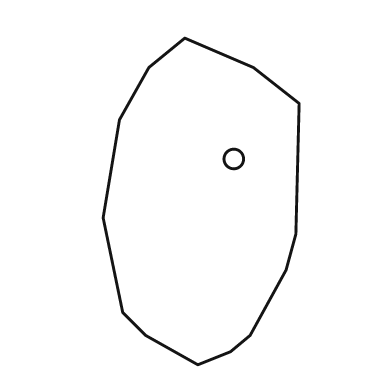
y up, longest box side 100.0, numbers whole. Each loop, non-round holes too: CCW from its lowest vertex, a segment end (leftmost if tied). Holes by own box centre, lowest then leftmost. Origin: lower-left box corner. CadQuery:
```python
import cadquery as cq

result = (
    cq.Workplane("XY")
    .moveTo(29.0, 0.0)
    .lineTo(39.0, 4.0)
    .lineTo(45.0, 9.0)
    .lineTo(56.0, 29.0)
    .lineTo(59.0, 40.0)
    .lineTo(60.0, 80.0)
    .lineTo(46.0, 91.0)
    .lineTo(25.0, 100.0)
    .lineTo(14.0, 91.0)
    .lineTo(5.0, 75.0)
    .lineTo(0.0, 45.0)
    .lineTo(6.0, 16.0)
    .lineTo(13.0, 9.0)
    .close()
    .moveTo(40.0, 63.0)
    .circle(3.0)
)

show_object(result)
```